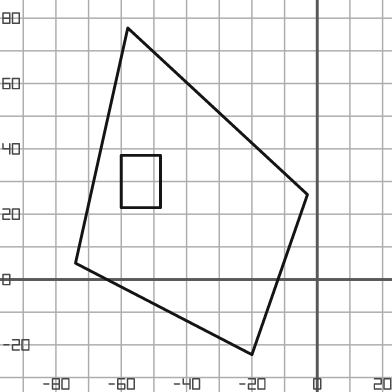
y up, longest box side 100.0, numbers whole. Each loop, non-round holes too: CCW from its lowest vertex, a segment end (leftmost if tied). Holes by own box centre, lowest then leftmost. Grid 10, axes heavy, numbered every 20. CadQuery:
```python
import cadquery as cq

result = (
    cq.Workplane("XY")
    .moveTo(-20.0, -23.0)
    .lineTo(-3.0, 26.0)
    .lineTo(-58.0, 77.0)
    .lineTo(-74.0, 5.0)
    .close()
    .moveTo(-60.0, 22.0)
    .lineTo(-48.0, 22.0)
    .lineTo(-48.0, 38.0)
    .lineTo(-60.0, 38.0)
    .close()
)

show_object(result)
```